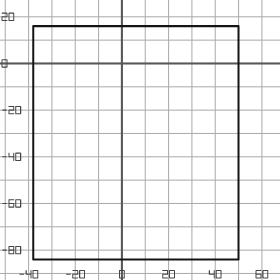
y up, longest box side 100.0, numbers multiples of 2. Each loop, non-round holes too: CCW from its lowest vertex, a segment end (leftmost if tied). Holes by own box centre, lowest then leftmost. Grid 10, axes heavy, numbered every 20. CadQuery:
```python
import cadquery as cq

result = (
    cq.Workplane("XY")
    .moveTo(-38.0, -84.0)
    .lineTo(50.0, -84.0)
    .lineTo(50.0, 16.0)
    .lineTo(-38.0, 16.0)
    .close()
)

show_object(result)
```